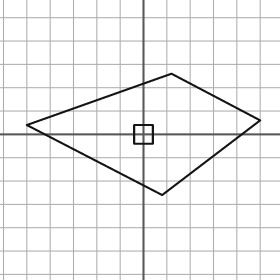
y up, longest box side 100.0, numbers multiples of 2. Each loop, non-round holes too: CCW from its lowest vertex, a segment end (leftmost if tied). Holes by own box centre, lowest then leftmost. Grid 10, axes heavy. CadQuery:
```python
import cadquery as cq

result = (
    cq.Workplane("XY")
    .moveTo(8.0, -26.0)
    .lineTo(50.0, 6.0)
    .lineTo(12.0, 26.0)
    .lineTo(-50.0, 4.0)
    .close()
    .moveTo(-4.0, -4.0)
    .lineTo(4.0, -4.0)
    .lineTo(4.0, 4.0)
    .lineTo(-4.0, 4.0)
    .close()
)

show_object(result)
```